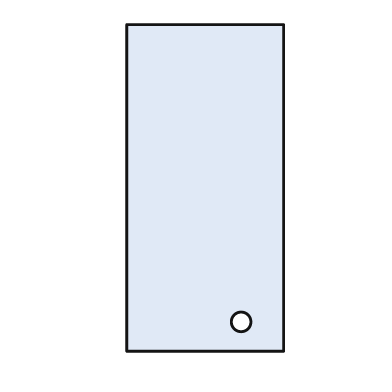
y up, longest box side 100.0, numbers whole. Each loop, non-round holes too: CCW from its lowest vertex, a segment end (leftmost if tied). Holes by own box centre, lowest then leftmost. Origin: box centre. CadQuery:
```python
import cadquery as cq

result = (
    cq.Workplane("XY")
    .moveTo(-24.0, -50.0)
    .lineTo(24.0, -50.0)
    .lineTo(24.0, 50.0)
    .lineTo(-24.0, 50.0)
    .close()
    .moveTo(11.0, -41.0)
    .circle(3.0)
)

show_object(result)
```